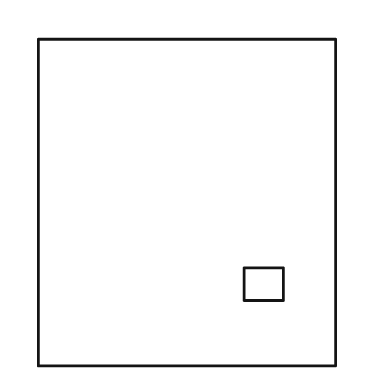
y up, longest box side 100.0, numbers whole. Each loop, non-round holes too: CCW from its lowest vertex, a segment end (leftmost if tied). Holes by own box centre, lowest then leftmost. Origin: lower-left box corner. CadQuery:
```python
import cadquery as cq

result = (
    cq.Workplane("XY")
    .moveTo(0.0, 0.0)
    .lineTo(91.0, 0.0)
    .lineTo(91.0, 100.0)
    .lineTo(0.0, 100.0)
    .close()
    .moveTo(63.0, 20.0)
    .lineTo(75.0, 20.0)
    .lineTo(75.0, 30.0)
    .lineTo(63.0, 30.0)
    .close()
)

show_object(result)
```